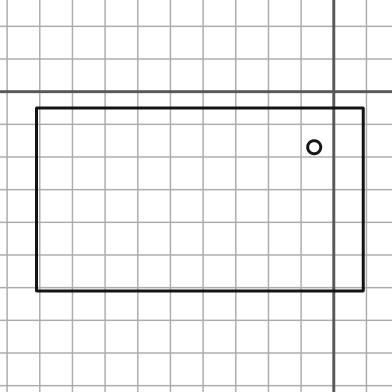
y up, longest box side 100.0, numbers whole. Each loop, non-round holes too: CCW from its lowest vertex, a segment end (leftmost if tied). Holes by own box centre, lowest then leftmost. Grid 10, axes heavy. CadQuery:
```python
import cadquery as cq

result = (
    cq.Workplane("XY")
    .moveTo(-91.0, -61.0)
    .lineTo(9.0, -61.0)
    .lineTo(9.0, -5.0)
    .lineTo(-91.0, -5.0)
    .close()
    .moveTo(-6.0, -17.0)
    .circle(2.0)
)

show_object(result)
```